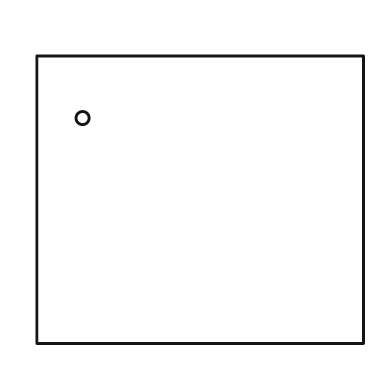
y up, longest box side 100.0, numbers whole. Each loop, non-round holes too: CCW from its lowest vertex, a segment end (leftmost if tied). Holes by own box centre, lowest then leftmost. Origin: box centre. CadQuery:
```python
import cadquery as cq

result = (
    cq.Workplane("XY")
    .moveTo(-50.0, -44.0)
    .lineTo(50.0, -44.0)
    .lineTo(50.0, 44.0)
    .lineTo(-50.0, 44.0)
    .close()
    .moveTo(-36.0, 25.0)
    .circle(2.0)
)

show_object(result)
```